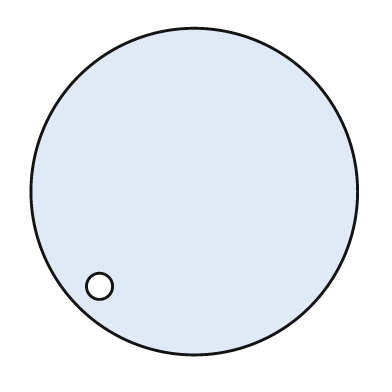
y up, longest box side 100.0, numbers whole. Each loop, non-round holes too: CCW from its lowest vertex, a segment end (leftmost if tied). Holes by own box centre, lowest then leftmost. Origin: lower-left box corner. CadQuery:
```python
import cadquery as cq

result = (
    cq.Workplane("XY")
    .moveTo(50.0, 50.0)
    .circle(50.0)
    .moveTo(21.0, 21.0)
    .circle(4.0)
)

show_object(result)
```